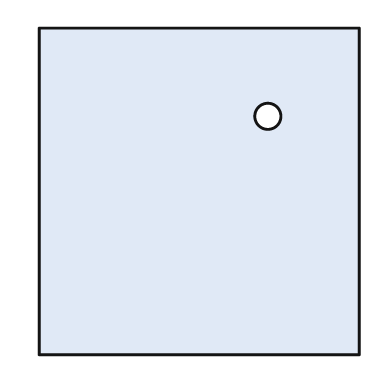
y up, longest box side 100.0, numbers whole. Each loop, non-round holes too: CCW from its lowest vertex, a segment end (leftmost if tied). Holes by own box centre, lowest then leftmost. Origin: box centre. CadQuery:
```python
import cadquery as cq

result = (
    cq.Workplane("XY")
    .moveTo(-49.0, -50.0)
    .lineTo(49.0, -50.0)
    .lineTo(49.0, 50.0)
    .lineTo(-49.0, 50.0)
    .close()
    .moveTo(21.0, 23.0)
    .circle(4.0)
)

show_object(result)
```